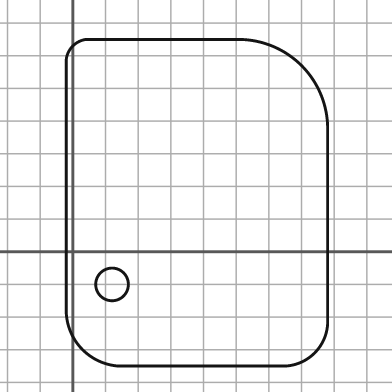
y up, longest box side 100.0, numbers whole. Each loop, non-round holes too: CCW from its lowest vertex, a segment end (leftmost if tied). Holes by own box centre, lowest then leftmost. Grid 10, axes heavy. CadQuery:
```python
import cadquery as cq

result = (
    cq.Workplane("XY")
    .moveTo(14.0, -35.0)
    .lineTo(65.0, -35.0)
    .threePointArc((74.0, -31.0), (78.0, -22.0))
    .lineTo(78.0, 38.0)
    .threePointArc((70.0, 57.0), (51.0, 65.0))
    .lineTo(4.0, 65.0)
    .threePointArc((0.0, 63.0), (-2.0, 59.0))
    .lineTo(-2.0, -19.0)
    .threePointArc((3.0, -30.0), (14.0, -35.0))
    .close()
    .moveTo(12.0, -10.0)
    .circle(5.0)
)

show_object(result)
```